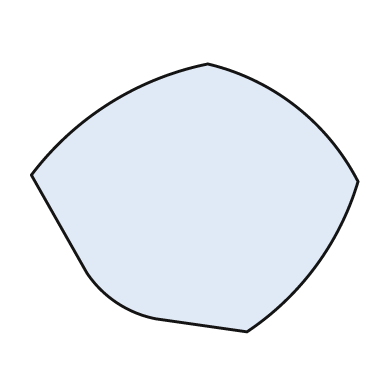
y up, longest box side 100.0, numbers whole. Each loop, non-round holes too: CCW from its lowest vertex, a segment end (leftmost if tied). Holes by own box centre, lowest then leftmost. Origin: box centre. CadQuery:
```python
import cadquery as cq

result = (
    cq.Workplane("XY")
    .moveTo(16.0, -41.0)
    .threePointArc((37.0, -21.0), (50.0, 5.0))
    .threePointArc((31.0, 28.0), (4.0, 41.0))
    .threePointArc((-26.0, 29.0), (-50.0, 7.0))
    .lineTo(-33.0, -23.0)
    .threePointArc((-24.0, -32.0), (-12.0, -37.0))
    .close()
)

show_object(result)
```